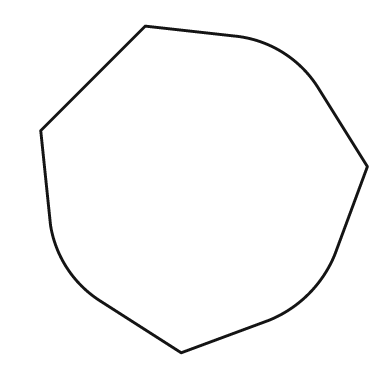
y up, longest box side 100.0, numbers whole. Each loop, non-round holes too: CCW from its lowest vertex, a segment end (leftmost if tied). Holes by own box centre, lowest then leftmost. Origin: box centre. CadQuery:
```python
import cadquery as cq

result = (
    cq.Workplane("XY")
    .moveTo(-7.0, -50.0)
    .lineTo(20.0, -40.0)
    .threePointArc((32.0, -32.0), (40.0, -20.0))
    .lineTo(50.0, 7.0)
    .lineTo(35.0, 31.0)
    .threePointArc((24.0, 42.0), (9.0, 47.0))
    .lineTo(-18.0, 50.0)
    .lineTo(-50.0, 18.0)
    .lineTo(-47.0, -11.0)
    .threePointArc((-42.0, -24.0), (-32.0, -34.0))
    .close()
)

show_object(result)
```